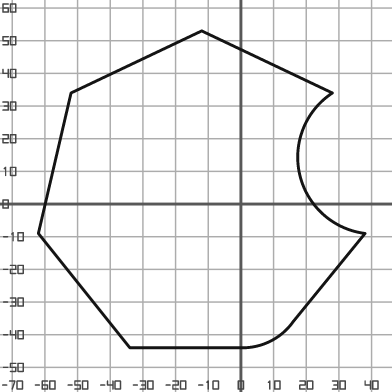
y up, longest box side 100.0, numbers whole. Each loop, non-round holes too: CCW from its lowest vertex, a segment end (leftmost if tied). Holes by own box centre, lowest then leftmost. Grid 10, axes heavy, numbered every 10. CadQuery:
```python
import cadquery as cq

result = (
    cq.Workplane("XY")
    .moveTo(-34.0, -44.0)
    .lineTo(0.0, -44.0)
    .threePointArc((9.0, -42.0), (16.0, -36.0))
    .lineTo(38.0, -9.0)
    .threePointArc((18.0, 9.0), (28.0, 34.0))
    .lineTo(-12.0, 53.0)
    .lineTo(-52.0, 34.0)
    .lineTo(-62.0, -9.0)
    .close()
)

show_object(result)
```